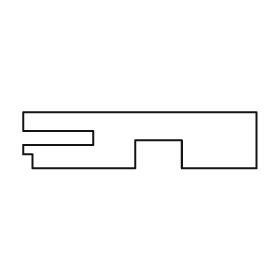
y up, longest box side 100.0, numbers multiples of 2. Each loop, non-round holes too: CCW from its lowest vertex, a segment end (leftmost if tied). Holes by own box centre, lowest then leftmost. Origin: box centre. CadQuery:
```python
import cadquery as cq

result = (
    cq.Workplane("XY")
    .moveTo(-46.0, -12.0)
    .lineTo(-2.0, -12.0)
    .lineTo(-2.0, 0.0)
    .lineTo(18.0, 0.0)
    .lineTo(18.0, -12.0)
    .lineTo(50.0, -12.0)
    .lineTo(50.0, 12.0)
    .lineTo(-50.0, 12.0)
    .lineTo(-50.0, 4.0)
    .lineTo(-20.0, 4.0)
    .lineTo(-20.0, -2.0)
    .lineTo(-50.0, -2.0)
    .lineTo(-50.0, -6.0)
    .lineTo(-46.0, -6.0)
    .close()
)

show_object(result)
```